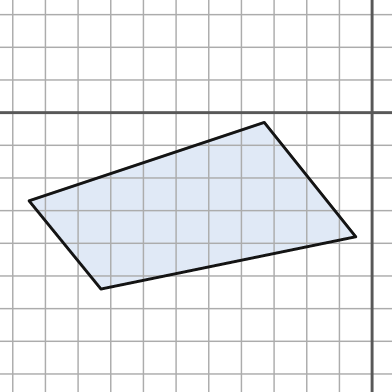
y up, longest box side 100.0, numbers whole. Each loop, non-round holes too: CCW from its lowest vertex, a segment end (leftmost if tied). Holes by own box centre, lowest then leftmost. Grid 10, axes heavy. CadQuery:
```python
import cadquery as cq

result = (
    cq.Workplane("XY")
    .moveTo(-83.0, -54.0)
    .lineTo(-5.0, -38.0)
    .lineTo(-33.0, -3.0)
    .lineTo(-105.0, -27.0)
    .close()
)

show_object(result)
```